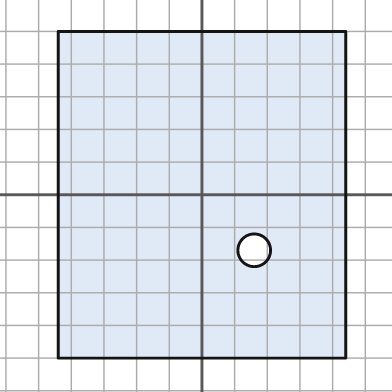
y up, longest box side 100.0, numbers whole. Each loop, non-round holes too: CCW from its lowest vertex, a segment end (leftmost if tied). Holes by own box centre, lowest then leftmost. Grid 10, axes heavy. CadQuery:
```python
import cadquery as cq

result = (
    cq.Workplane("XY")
    .moveTo(-44.0, -50.0)
    .lineTo(44.0, -50.0)
    .lineTo(44.0, 50.0)
    .lineTo(-44.0, 50.0)
    .close()
    .moveTo(16.0, -17.0)
    .circle(5.0)
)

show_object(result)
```